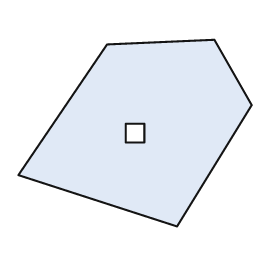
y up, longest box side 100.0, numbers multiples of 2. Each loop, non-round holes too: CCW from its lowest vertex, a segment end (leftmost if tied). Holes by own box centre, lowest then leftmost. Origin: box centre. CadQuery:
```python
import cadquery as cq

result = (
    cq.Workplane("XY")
    .moveTo(18.0, -40.0)
    .lineTo(50.0, 12.0)
    .lineTo(34.0, 40.0)
    .lineTo(-12.0, 38.0)
    .lineTo(-50.0, -18.0)
    .close()
    .moveTo(-4.0, -4.0)
    .lineTo(4.0, -4.0)
    .lineTo(4.0, 4.0)
    .lineTo(-4.0, 4.0)
    .close()
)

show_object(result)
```